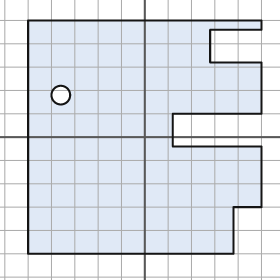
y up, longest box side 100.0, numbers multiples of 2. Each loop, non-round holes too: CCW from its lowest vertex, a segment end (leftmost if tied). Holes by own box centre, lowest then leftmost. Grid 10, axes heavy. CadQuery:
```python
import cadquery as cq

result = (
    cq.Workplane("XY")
    .moveTo(-50.0, -50.0)
    .lineTo(38.0, -50.0)
    .lineTo(38.0, -30.0)
    .lineTo(50.0, -30.0)
    .lineTo(50.0, -4.0)
    .lineTo(12.0, -4.0)
    .lineTo(12.0, 10.0)
    .lineTo(50.0, 10.0)
    .lineTo(50.0, 32.0)
    .lineTo(28.0, 32.0)
    .lineTo(28.0, 46.0)
    .lineTo(50.0, 46.0)
    .lineTo(50.0, 50.0)
    .lineTo(-50.0, 50.0)
    .close()
    .moveTo(-36.0, 18.0)
    .circle(4.0)
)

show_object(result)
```